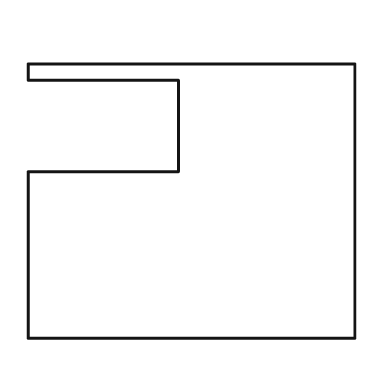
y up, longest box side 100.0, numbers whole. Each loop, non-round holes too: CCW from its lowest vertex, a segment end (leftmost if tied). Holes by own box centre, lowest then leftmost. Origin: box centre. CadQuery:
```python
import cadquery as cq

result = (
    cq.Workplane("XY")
    .moveTo(-50.0, -42.0)
    .lineTo(50.0, -42.0)
    .lineTo(50.0, 42.0)
    .lineTo(-50.0, 42.0)
    .lineTo(-50.0, 37.0)
    .lineTo(-4.0, 37.0)
    .lineTo(-4.0, 9.0)
    .lineTo(-50.0, 9.0)
    .close()
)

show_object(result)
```